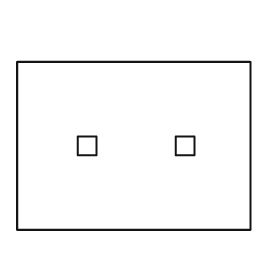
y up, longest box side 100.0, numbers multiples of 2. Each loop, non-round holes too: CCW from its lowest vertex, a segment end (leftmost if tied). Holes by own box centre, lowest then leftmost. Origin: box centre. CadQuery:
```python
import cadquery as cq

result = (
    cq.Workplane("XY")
    .moveTo(-50.0, -36.0)
    .lineTo(50.0, -36.0)
    .lineTo(50.0, 36.0)
    .lineTo(-50.0, 36.0)
    .close()
    .moveTo(-24.0, -4.0)
    .lineTo(-16.0, -4.0)
    .lineTo(-16.0, 4.0)
    .lineTo(-24.0, 4.0)
    .close()
    .moveTo(18.0, -4.0)
    .lineTo(26.0, -4.0)
    .lineTo(26.0, 4.0)
    .lineTo(18.0, 4.0)
    .close()
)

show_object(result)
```